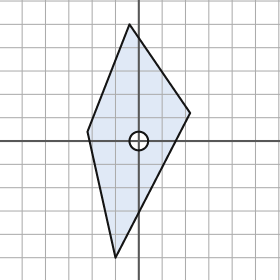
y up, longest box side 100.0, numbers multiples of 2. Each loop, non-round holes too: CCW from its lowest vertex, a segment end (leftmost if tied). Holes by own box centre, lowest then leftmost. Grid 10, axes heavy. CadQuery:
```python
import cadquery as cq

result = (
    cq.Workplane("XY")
    .moveTo(-10.0, -50.0)
    .lineTo(22.0, 12.0)
    .lineTo(-4.0, 50.0)
    .lineTo(-22.0, 4.0)
    .close()
    .moveTo(0.0, 0.0)
    .circle(4.0)
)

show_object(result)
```